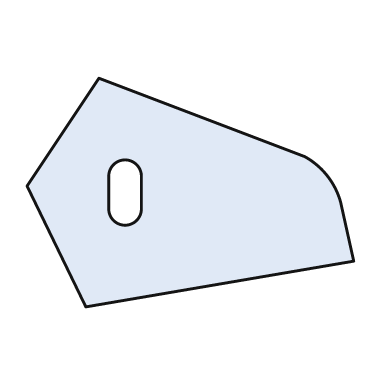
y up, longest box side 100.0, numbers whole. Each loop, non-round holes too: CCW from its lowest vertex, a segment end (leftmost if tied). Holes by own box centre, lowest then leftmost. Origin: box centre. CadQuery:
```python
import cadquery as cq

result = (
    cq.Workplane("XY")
    .moveTo(-32.0, -35.0)
    .lineTo(50.0, -21.0)
    .lineTo(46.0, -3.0)
    .threePointArc((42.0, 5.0), (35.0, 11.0))
    .lineTo(-28.0, 35.0)
    .lineTo(-50.0, 2.0)
    .close()
    .moveTo(-25.0, -5.0)
    .threePointArc((-20.0, -10.0), (-15.0, -5.0))
    .lineTo(-15.0, 5.0)
    .threePointArc((-20.0, 10.0), (-25.0, 5.0))
    .close()
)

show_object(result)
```